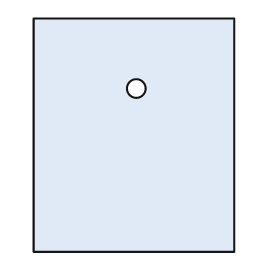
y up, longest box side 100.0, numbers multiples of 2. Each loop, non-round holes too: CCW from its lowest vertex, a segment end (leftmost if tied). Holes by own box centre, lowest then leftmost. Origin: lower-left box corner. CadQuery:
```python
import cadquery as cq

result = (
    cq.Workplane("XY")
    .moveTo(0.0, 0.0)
    .lineTo(86.0, 0.0)
    .lineTo(86.0, 100.0)
    .lineTo(0.0, 100.0)
    .close()
    .moveTo(44.0, 70.0)
    .circle(4.0)
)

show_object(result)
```